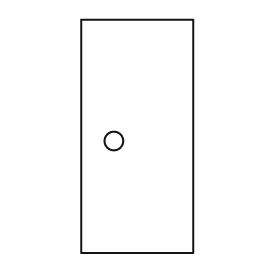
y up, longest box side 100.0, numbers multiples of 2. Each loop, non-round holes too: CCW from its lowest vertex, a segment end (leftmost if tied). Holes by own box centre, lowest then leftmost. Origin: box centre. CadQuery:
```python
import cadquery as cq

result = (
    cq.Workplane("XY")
    .moveTo(-24.0, -50.0)
    .lineTo(24.0, -50.0)
    .lineTo(24.0, 50.0)
    .lineTo(-24.0, 50.0)
    .close()
    .moveTo(-10.0, -2.0)
    .circle(4.0)
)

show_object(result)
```